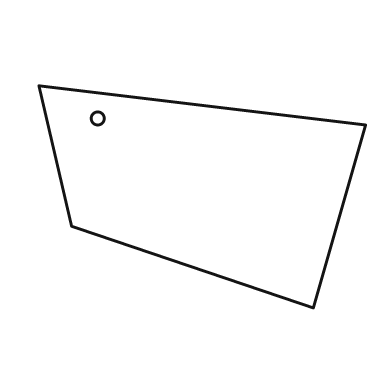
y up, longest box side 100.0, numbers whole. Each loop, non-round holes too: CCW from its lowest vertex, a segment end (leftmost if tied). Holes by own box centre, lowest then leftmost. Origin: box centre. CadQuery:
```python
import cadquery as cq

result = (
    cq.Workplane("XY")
    .moveTo(34.0, -34.0)
    .lineTo(50.0, 22.0)
    .lineTo(-50.0, 34.0)
    .lineTo(-40.0, -9.0)
    .close()
    .moveTo(-32.0, 24.0)
    .circle(2.0)
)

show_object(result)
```